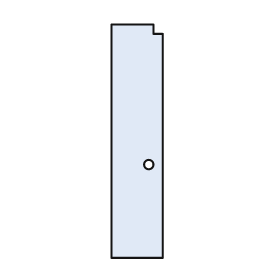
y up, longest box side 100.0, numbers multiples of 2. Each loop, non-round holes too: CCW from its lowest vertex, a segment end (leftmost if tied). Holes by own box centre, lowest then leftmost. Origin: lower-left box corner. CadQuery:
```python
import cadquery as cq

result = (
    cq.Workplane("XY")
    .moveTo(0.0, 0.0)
    .lineTo(22.0, 0.0)
    .lineTo(22.0, 96.0)
    .lineTo(18.0, 96.0)
    .lineTo(18.0, 100.0)
    .lineTo(0.0, 100.0)
    .close()
    .moveTo(16.0, 40.0)
    .circle(2.0)
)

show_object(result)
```